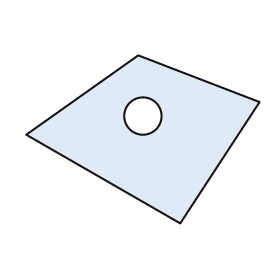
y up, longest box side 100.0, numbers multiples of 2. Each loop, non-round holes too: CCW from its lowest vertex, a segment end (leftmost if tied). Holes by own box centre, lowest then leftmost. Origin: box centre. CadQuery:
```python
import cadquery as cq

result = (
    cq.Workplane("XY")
    .moveTo(16.0, -36.0)
    .lineTo(50.0, 16.0)
    .lineTo(-2.0, 36.0)
    .lineTo(-50.0, 2.0)
    .close()
    .moveTo(0.0, 10.0)
    .circle(8.0)
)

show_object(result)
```